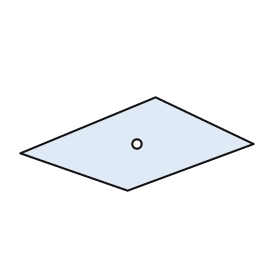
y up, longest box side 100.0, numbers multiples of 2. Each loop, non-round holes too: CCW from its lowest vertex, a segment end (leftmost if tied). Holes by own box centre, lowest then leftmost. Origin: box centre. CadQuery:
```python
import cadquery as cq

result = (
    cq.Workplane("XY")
    .moveTo(-4.0, -20.0)
    .lineTo(50.0, 0.0)
    .lineTo(8.0, 20.0)
    .lineTo(-50.0, -4.0)
    .close()
    .moveTo(0.0, 0.0)
    .circle(2.0)
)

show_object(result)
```